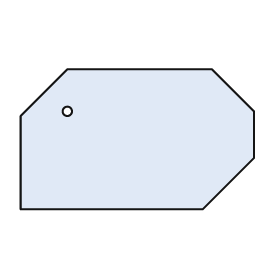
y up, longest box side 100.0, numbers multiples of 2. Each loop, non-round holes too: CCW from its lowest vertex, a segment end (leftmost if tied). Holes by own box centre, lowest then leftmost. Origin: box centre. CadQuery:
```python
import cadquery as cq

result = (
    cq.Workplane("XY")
    .moveTo(-50.0, -30.0)
    .lineTo(28.0, -30.0)
    .lineTo(50.0, -8.0)
    .lineTo(50.0, 12.0)
    .lineTo(32.0, 30.0)
    .lineTo(-30.0, 30.0)
    .lineTo(-50.0, 10.0)
    .close()
    .moveTo(-30.0, 12.0)
    .circle(2.0)
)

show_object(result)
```